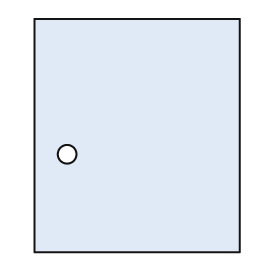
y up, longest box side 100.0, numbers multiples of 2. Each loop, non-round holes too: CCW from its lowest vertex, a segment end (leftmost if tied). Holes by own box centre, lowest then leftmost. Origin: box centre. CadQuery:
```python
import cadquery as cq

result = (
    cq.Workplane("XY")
    .moveTo(-44.0, -50.0)
    .lineTo(44.0, -50.0)
    .lineTo(44.0, 50.0)
    .lineTo(-44.0, 50.0)
    .close()
    .moveTo(-30.0, -8.0)
    .circle(4.0)
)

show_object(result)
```